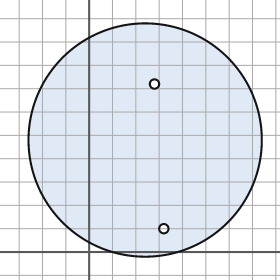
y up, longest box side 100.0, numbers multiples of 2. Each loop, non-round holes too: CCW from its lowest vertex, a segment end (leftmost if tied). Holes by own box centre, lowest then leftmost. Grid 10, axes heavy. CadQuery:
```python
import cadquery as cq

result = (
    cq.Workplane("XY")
    .moveTo(24.0, 48.0)
    .circle(50.0)
    .moveTo(32.0, 10.0)
    .circle(2.0)
    .moveTo(28.0, 72.0)
    .circle(2.0)
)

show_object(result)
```